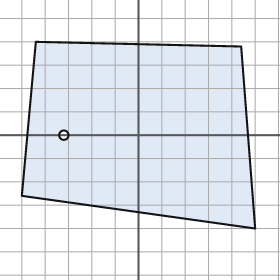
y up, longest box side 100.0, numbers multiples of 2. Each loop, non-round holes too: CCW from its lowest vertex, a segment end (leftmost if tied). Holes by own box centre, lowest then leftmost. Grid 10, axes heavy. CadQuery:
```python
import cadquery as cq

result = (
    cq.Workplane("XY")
    .moveTo(50.0, -40.0)
    .lineTo(44.0, 38.0)
    .lineTo(-44.0, 40.0)
    .lineTo(-50.0, -26.0)
    .close()
    .moveTo(-32.0, 0.0)
    .circle(2.0)
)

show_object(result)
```